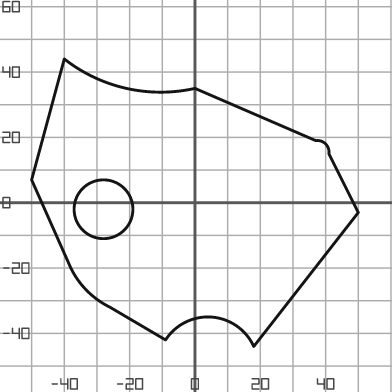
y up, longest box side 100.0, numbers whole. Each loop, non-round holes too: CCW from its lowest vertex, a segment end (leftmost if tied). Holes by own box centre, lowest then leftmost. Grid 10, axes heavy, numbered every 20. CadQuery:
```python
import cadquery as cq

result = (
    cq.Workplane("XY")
    .moveTo(18.0, -44.0)
    .lineTo(50.0, -3.0)
    .lineTo(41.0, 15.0)
    .threePointArc((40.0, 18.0), (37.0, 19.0))
    .lineTo(0.0, 35.0)
    .threePointArc((-21.0, 35.0), (-40.0, 44.0))
    .lineTo(-50.0, 7.0)
    .lineTo(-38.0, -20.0)
    .threePointArc((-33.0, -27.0), (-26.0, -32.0))
    .lineTo(-9.0, -42.0)
    .threePointArc((5.0, -35.0), (18.0, -44.0))
    .close()
    .moveTo(-28.0, -2.0)
    .circle(9.0)
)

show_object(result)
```